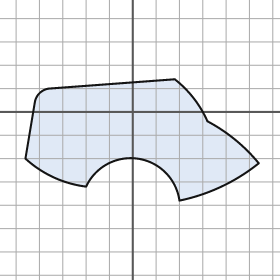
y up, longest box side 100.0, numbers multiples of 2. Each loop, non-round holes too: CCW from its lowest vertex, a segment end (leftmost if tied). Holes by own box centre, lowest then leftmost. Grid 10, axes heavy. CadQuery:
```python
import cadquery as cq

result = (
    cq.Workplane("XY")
    .moveTo(20.0, -38.0)
    .threePointArc((38.0, -32.0), (54.0, -22.0))
    .threePointArc((44.0, -12.0), (32.0, -4.0))
    .threePointArc((26.0, 6.0), (18.0, 14.0))
    .lineTo(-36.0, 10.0)
    .threePointArc((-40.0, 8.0), (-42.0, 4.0))
    .lineTo(-46.0, -20.0)
    .threePointArc((-34.0, -28.0), (-20.0, -32.0))
    .threePointArc((2.0, -20.0), (20.0, -38.0))
    .close()
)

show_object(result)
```